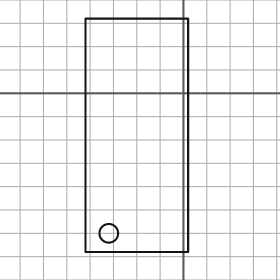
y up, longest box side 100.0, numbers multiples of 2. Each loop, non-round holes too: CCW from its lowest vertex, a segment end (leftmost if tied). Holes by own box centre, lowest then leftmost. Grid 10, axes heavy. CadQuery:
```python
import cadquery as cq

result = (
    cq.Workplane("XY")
    .moveTo(-42.0, -68.0)
    .lineTo(2.0, -68.0)
    .lineTo(2.0, 32.0)
    .lineTo(-42.0, 32.0)
    .close()
    .moveTo(-32.0, -60.0)
    .circle(4.0)
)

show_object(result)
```